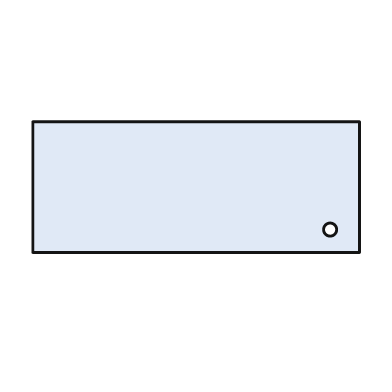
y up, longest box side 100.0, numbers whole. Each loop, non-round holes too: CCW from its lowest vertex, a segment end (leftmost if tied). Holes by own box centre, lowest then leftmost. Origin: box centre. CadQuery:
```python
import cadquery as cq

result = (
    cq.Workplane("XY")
    .moveTo(-50.0, -20.0)
    .lineTo(50.0, -20.0)
    .lineTo(50.0, 20.0)
    .lineTo(-50.0, 20.0)
    .close()
    .moveTo(41.0, -13.0)
    .circle(2.0)
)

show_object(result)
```